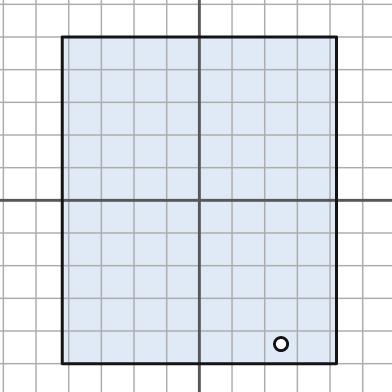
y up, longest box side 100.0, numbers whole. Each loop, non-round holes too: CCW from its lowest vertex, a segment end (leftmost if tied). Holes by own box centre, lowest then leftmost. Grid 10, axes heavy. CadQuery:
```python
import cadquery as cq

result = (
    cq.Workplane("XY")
    .moveTo(-42.0, -50.0)
    .lineTo(42.0, -50.0)
    .lineTo(42.0, 50.0)
    .lineTo(-42.0, 50.0)
    .close()
    .moveTo(25.0, -44.0)
    .circle(2.0)
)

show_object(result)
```